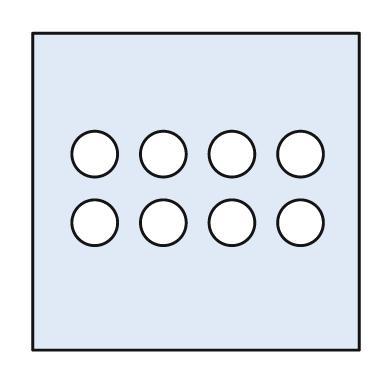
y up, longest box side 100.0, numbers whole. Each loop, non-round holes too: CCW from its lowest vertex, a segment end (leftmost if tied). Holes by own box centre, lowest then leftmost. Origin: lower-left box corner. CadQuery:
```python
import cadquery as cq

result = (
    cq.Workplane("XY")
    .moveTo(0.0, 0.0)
    .lineTo(100.0, 0.0)
    .lineTo(100.0, 97.0)
    .lineTo(0.0, 97.0)
    .close()
    .moveTo(19.0, 39.0)
    .circle(7.0)
    .moveTo(40.0, 39.0)
    .circle(7.0)
    .moveTo(61.0, 39.0)
    .circle(7.0)
    .moveTo(82.0, 39.0)
    .circle(7.0)
    .moveTo(19.0, 60.0)
    .circle(7.0)
    .moveTo(40.0, 60.0)
    .circle(7.0)
    .moveTo(61.0, 60.0)
    .circle(7.0)
    .moveTo(82.0, 60.0)
    .circle(7.0)
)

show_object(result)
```